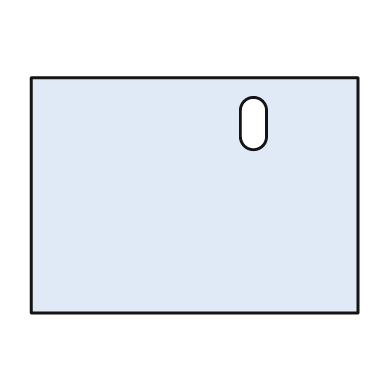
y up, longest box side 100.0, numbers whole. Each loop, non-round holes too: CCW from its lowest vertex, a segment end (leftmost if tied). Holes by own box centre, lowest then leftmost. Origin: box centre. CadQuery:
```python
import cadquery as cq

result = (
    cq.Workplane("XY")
    .moveTo(-50.0, -36.0)
    .lineTo(50.0, -36.0)
    .lineTo(50.0, 36.0)
    .lineTo(-50.0, 36.0)
    .close()
    .moveTo(14.0, 18.0)
    .threePointArc((18.0, 14.0), (22.0, 18.0))
    .lineTo(22.0, 26.0)
    .threePointArc((18.0, 30.0), (14.0, 26.0))
    .close()
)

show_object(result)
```